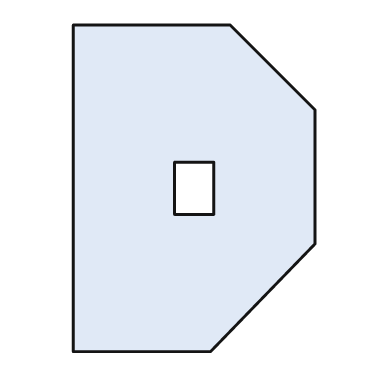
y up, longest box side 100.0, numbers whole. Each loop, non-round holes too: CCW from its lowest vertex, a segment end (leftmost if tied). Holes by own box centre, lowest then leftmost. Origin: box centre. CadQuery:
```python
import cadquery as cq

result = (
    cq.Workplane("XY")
    .moveTo(-37.0, -50.0)
    .lineTo(5.0, -50.0)
    .lineTo(37.0, -17.0)
    .lineTo(37.0, 24.0)
    .lineTo(11.0, 50.0)
    .lineTo(-37.0, 50.0)
    .close()
    .moveTo(-6.0, -8.0)
    .lineTo(6.0, -8.0)
    .lineTo(6.0, 8.0)
    .lineTo(-6.0, 8.0)
    .close()
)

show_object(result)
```